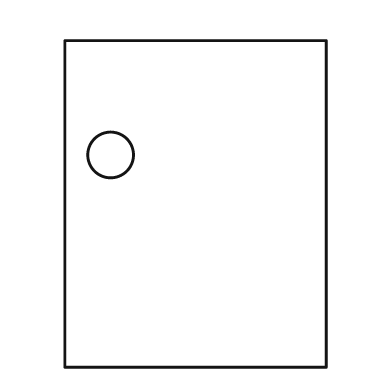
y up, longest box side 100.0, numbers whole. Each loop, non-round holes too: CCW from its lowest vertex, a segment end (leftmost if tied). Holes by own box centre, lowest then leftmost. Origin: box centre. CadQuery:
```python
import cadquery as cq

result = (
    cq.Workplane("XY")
    .moveTo(-40.0, -50.0)
    .lineTo(40.0, -50.0)
    .lineTo(40.0, 50.0)
    .lineTo(-40.0, 50.0)
    .close()
    .moveTo(-26.0, 15.0)
    .circle(7.0)
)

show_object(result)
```